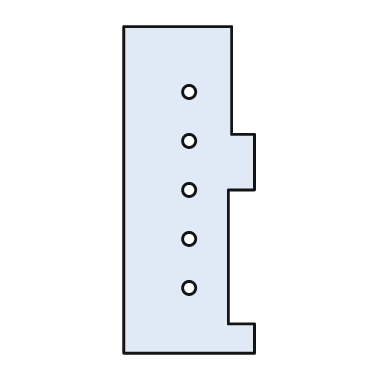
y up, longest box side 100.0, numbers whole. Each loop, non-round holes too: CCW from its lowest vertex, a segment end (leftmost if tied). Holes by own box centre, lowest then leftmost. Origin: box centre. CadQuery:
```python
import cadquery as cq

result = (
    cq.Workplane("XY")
    .moveTo(-20.0, -50.0)
    .lineTo(20.0, -50.0)
    .lineTo(20.0, -41.0)
    .lineTo(12.0, -41.0)
    .lineTo(12.0, 0.0)
    .lineTo(20.0, 0.0)
    .lineTo(20.0, 17.0)
    .lineTo(13.0, 17.0)
    .lineTo(13.0, 50.0)
    .lineTo(-20.0, 50.0)
    .close()
    .moveTo(0.0, -30.0)
    .circle(2.0)
    .moveTo(0.0, -15.0)
    .circle(2.0)
    .moveTo(0.0, 0.0)
    .circle(2.0)
    .moveTo(0.0, 15.0)
    .circle(2.0)
    .moveTo(0.0, 30.0)
    .circle(2.0)
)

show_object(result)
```